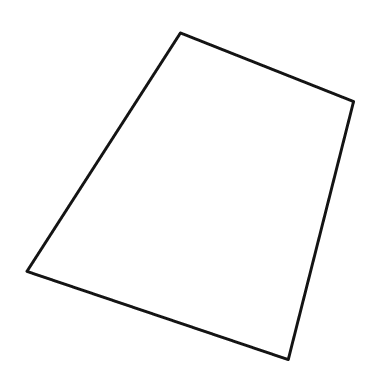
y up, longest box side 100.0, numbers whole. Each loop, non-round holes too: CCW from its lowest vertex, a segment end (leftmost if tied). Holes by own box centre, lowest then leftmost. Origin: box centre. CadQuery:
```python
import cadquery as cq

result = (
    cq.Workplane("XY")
    .moveTo(30.0, -50.0)
    .lineTo(50.0, 29.0)
    .lineTo(-3.0, 50.0)
    .lineTo(-50.0, -23.0)
    .close()
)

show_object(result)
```